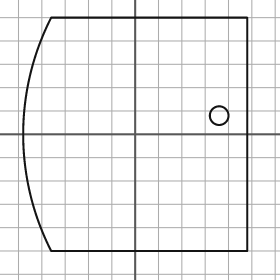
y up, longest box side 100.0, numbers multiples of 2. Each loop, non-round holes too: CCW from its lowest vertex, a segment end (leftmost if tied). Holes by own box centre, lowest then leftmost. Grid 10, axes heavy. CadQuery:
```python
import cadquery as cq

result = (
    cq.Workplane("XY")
    .moveTo(-36.0, -50.0)
    .lineTo(48.0, -50.0)
    .lineTo(48.0, 50.0)
    .lineTo(-36.0, 50.0)
    .threePointArc((-48.0, 0.0), (-36.0, -50.0))
    .close()
    .moveTo(36.0, 8.0)
    .circle(4.0)
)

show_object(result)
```